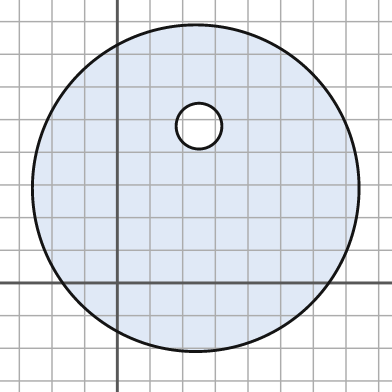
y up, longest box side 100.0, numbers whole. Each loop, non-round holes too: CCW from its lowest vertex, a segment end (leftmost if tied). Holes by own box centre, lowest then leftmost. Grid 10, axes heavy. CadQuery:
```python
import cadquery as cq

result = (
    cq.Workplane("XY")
    .moveTo(24.0, 29.0)
    .circle(50.0)
    .moveTo(25.0, 48.0)
    .circle(7.0)
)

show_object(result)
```